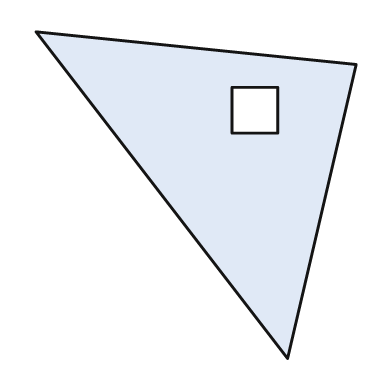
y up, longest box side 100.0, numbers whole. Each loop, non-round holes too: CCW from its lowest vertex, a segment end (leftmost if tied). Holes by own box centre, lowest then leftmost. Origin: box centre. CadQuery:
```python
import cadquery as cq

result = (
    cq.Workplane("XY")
    .moveTo(28.0, -50.0)
    .lineTo(49.0, 40.0)
    .lineTo(-49.0, 50.0)
    .close()
    .moveTo(11.0, 19.0)
    .lineTo(25.0, 19.0)
    .lineTo(25.0, 33.0)
    .lineTo(11.0, 33.0)
    .close()
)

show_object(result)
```